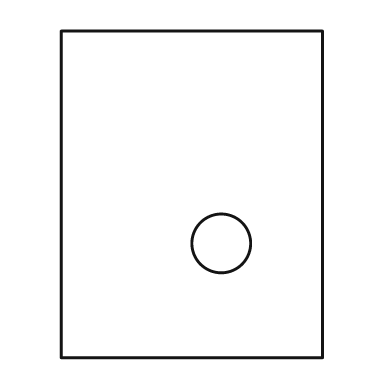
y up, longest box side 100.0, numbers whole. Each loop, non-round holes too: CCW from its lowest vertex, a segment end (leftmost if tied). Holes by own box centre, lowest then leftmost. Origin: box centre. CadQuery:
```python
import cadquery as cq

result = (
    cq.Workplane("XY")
    .moveTo(-40.0, -50.0)
    .lineTo(40.0, -50.0)
    .lineTo(40.0, 50.0)
    .lineTo(-40.0, 50.0)
    .close()
    .moveTo(9.0, -15.0)
    .circle(9.0)
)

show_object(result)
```